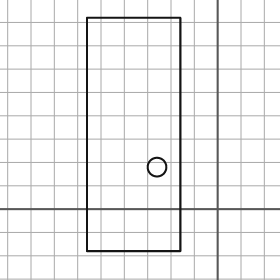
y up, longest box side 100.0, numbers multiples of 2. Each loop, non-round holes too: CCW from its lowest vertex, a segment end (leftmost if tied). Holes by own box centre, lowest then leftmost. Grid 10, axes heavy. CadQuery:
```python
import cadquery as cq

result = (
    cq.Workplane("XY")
    .moveTo(-56.0, -18.0)
    .lineTo(-16.0, -18.0)
    .lineTo(-16.0, 82.0)
    .lineTo(-56.0, 82.0)
    .close()
    .moveTo(-26.0, 18.0)
    .circle(4.0)
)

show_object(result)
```